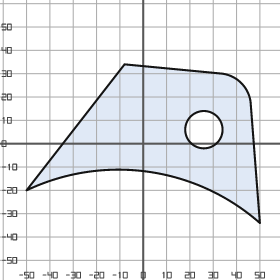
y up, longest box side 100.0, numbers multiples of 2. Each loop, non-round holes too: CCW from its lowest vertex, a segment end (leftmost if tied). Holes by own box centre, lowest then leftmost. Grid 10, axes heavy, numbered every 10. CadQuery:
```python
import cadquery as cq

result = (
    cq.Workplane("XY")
    .moveTo(50.0, -34.0)
    .lineTo(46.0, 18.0)
    .threePointArc((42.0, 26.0), (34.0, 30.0))
    .lineTo(-8.0, 34.0)
    .lineTo(-50.0, -20.0)
    .threePointArc((2.0, -12.0), (50.0, -34.0))
    .close()
    .moveTo(26.0, 6.0)
    .circle(8.0)
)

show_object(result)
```